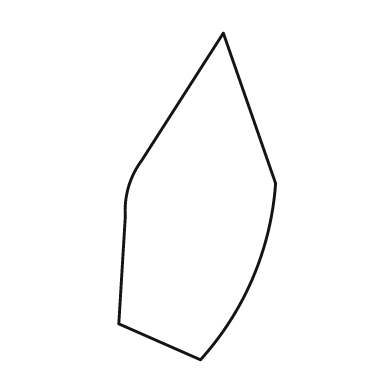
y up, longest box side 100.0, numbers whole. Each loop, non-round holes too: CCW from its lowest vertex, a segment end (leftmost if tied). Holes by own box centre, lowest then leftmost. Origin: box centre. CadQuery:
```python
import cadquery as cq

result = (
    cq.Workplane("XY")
    .moveTo(1.0, -50.0)
    .threePointArc((17.0, -25.0), (24.0, 4.0))
    .lineTo(8.0, 50.0)
    .lineTo(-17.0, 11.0)
    .threePointArc((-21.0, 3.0), (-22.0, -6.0))
    .lineTo(-24.0, -39.0)
    .close()
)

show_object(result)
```